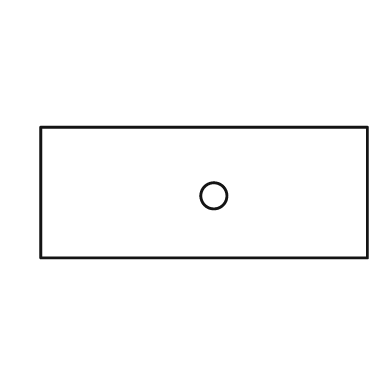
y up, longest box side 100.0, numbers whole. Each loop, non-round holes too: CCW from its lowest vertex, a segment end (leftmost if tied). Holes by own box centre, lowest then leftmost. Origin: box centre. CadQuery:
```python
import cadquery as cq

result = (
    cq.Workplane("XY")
    .moveTo(-50.0, -20.0)
    .lineTo(50.0, -20.0)
    .lineTo(50.0, 20.0)
    .lineTo(-50.0, 20.0)
    .close()
    .moveTo(3.0, -1.0)
    .circle(4.0)
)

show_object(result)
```